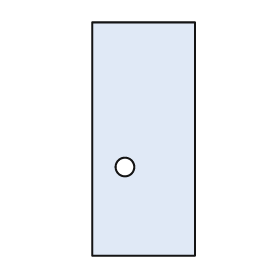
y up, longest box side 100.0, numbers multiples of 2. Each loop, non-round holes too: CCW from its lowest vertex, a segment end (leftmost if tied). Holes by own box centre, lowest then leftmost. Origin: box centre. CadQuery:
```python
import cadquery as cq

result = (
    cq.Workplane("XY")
    .moveTo(-22.0, -50.0)
    .lineTo(22.0, -50.0)
    .lineTo(22.0, 50.0)
    .lineTo(-22.0, 50.0)
    .close()
    .moveTo(-8.0, -12.0)
    .circle(4.0)
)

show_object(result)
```